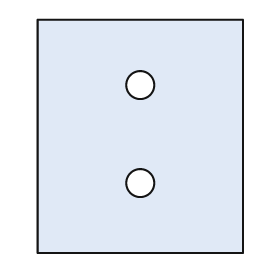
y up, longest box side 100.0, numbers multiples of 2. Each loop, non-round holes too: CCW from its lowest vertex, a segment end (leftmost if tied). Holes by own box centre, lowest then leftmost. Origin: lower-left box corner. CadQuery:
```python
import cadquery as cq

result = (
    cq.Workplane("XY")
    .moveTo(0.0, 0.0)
    .lineTo(88.0, 0.0)
    .lineTo(88.0, 100.0)
    .lineTo(0.0, 100.0)
    .close()
    .moveTo(44.0, 30.0)
    .circle(6.0)
    .moveTo(44.0, 72.0)
    .circle(6.0)
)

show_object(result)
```